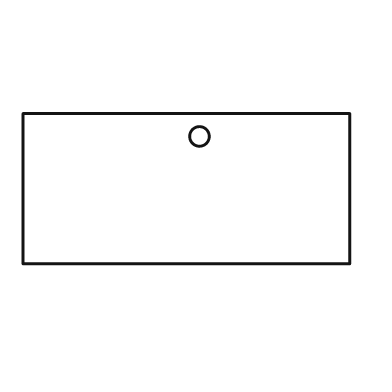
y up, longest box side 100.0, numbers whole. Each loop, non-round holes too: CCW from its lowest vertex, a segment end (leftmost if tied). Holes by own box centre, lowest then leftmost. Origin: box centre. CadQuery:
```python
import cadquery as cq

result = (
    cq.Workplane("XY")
    .moveTo(-50.0, -23.0)
    .lineTo(50.0, -23.0)
    .lineTo(50.0, 23.0)
    .lineTo(-50.0, 23.0)
    .close()
    .moveTo(4.0, 16.0)
    .circle(3.0)
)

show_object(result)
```